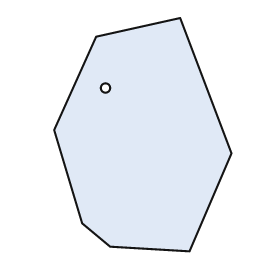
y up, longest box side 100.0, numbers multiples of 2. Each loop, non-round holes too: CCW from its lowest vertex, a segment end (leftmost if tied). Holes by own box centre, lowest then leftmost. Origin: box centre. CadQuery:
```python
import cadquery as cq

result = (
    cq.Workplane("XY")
    .moveTo(20.0, -50.0)
    .lineTo(38.0, -8.0)
    .lineTo(16.0, 50.0)
    .lineTo(-20.0, 42.0)
    .lineTo(-38.0, 2.0)
    .lineTo(-26.0, -38.0)
    .lineTo(-14.0, -48.0)
    .close()
    .moveTo(-16.0, 20.0)
    .circle(2.0)
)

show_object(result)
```